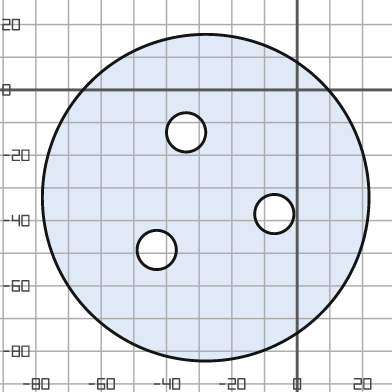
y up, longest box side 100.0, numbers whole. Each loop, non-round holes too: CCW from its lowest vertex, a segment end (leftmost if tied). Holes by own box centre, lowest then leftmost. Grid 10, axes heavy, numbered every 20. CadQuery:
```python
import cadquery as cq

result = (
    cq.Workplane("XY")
    .moveTo(-28.0, -33.0)
    .circle(50.0)
    .moveTo(-43.0, -49.0)
    .circle(6.0)
    .moveTo(-7.0, -38.0)
    .circle(6.0)
    .moveTo(-34.0, -13.0)
    .circle(6.0)
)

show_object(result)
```